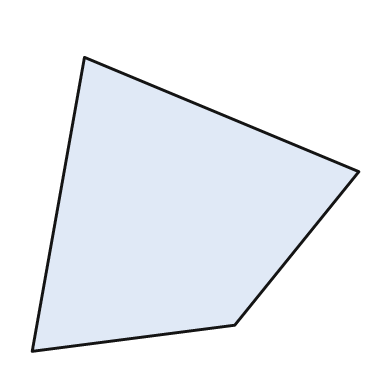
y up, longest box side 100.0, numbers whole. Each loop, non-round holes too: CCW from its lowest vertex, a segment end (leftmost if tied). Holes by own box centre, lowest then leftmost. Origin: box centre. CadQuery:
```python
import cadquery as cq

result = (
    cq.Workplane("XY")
    .moveTo(-50.0, -45.0)
    .lineTo(12.0, -37.0)
    .lineTo(50.0, 10.0)
    .lineTo(-34.0, 45.0)
    .close()
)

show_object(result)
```